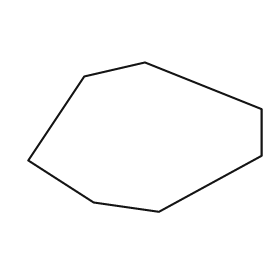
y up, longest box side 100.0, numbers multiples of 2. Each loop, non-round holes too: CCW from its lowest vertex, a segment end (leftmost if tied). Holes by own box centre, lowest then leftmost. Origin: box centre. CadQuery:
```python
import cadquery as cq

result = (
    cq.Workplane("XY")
    .moveTo(6.0, -32.0)
    .lineTo(50.0, -8.0)
    .lineTo(50.0, 12.0)
    .lineTo(0.0, 32.0)
    .lineTo(-26.0, 26.0)
    .lineTo(-50.0, -10.0)
    .lineTo(-22.0, -28.0)
    .close()
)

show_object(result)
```